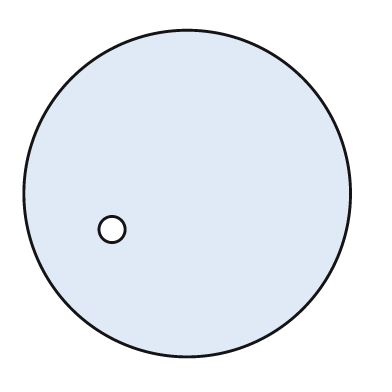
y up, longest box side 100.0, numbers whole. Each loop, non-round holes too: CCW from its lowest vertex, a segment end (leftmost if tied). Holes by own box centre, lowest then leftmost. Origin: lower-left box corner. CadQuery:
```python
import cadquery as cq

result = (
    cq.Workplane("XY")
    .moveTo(50.0, 50.0)
    .circle(50.0)
    .moveTo(27.0, 39.0)
    .circle(4.0)
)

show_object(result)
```